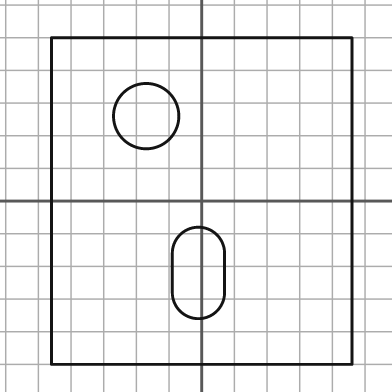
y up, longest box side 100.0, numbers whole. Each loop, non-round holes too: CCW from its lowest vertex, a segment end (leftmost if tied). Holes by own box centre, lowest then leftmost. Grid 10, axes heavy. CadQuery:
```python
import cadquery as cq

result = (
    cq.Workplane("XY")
    .moveTo(-46.0, -50.0)
    .lineTo(46.0, -50.0)
    .lineTo(46.0, 50.0)
    .lineTo(-46.0, 50.0)
    .close()
    .moveTo(-9.0, -28.0)
    .threePointArc((-1.0, -36.0), (7.0, -28.0))
    .lineTo(7.0, -16.0)
    .threePointArc((-1.0, -8.0), (-9.0, -16.0))
    .close()
    .moveTo(-17.0, 26.0)
    .circle(10.0)
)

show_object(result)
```